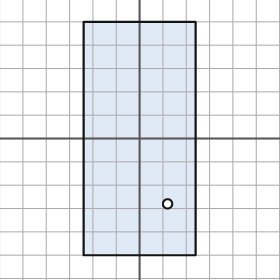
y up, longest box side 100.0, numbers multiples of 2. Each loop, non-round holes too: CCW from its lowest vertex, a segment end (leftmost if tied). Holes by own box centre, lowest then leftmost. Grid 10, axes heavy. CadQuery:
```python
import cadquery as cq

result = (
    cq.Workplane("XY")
    .moveTo(-24.0, -50.0)
    .lineTo(24.0, -50.0)
    .lineTo(24.0, 50.0)
    .lineTo(-24.0, 50.0)
    .close()
    .moveTo(12.0, -28.0)
    .circle(2.0)
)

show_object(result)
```